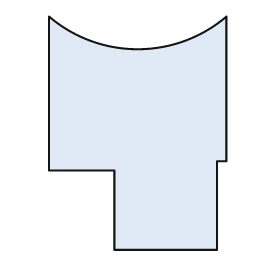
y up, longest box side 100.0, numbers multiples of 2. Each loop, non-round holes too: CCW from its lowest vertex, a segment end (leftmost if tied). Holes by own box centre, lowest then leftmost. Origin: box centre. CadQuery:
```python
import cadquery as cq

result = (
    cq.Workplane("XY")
    .moveTo(-10.0, -50.0)
    .lineTo(34.0, -50.0)
    .lineTo(34.0, -12.0)
    .lineTo(38.0, -12.0)
    .lineTo(38.0, 50.0)
    .threePointArc((0.0, 36.0), (-38.0, 50.0))
    .lineTo(-38.0, -16.0)
    .lineTo(-10.0, -16.0)
    .close()
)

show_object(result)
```